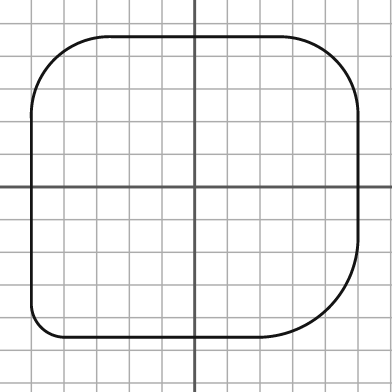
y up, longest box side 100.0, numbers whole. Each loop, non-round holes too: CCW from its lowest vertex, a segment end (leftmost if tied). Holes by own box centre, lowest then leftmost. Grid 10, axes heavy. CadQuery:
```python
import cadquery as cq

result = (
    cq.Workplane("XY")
    .moveTo(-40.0, -46.0)
    .lineTo(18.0, -46.0)
    .threePointArc((41.0, -37.0), (50.0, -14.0))
    .lineTo(50.0, 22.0)
    .threePointArc((43.0, 39.0), (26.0, 46.0))
    .lineTo(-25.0, 46.0)
    .threePointArc((-43.0, 39.0), (-50.0, 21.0))
    .lineTo(-50.0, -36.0)
    .threePointArc((-47.0, -43.0), (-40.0, -46.0))
    .close()
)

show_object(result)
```